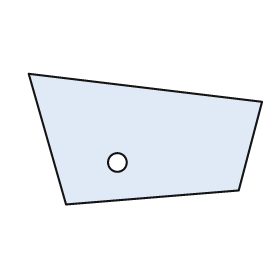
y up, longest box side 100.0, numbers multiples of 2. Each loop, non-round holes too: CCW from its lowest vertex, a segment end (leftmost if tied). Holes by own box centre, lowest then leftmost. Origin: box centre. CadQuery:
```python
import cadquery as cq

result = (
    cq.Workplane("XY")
    .moveTo(-34.0, -28.0)
    .lineTo(40.0, -22.0)
    .lineTo(50.0, 16.0)
    .lineTo(-50.0, 28.0)
    .close()
    .moveTo(-12.0, -10.0)
    .circle(4.0)
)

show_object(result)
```